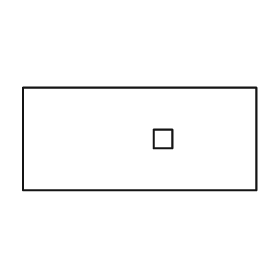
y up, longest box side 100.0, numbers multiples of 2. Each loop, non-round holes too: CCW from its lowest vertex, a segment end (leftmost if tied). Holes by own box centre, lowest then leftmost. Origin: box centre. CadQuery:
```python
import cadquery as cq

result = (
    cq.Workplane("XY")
    .moveTo(-50.0, -22.0)
    .lineTo(50.0, -22.0)
    .lineTo(50.0, 22.0)
    .lineTo(-50.0, 22.0)
    .close()
    .moveTo(6.0, -4.0)
    .lineTo(14.0, -4.0)
    .lineTo(14.0, 4.0)
    .lineTo(6.0, 4.0)
    .close()
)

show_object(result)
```